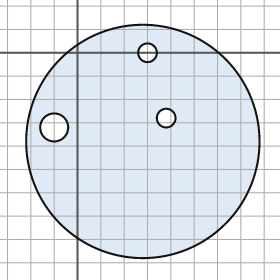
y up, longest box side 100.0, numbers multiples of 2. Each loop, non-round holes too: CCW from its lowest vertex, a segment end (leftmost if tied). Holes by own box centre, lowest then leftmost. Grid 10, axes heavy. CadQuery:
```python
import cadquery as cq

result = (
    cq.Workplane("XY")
    .moveTo(28.0, -38.0)
    .circle(50.0)
    .moveTo(-10.0, -32.0)
    .circle(6.0)
    .moveTo(38.0, -28.0)
    .circle(4.0)
    .moveTo(30.0, 0.0)
    .circle(4.0)
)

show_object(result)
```